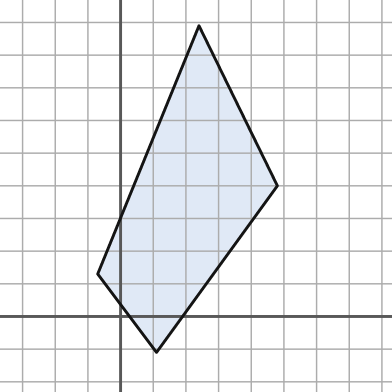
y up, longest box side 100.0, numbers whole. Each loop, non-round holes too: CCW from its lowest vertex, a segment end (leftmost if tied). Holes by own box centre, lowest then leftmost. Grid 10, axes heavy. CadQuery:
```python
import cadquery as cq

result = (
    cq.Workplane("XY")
    .moveTo(11.0, -11.0)
    .lineTo(48.0, 40.0)
    .lineTo(24.0, 89.0)
    .lineTo(-7.0, 13.0)
    .close()
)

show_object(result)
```